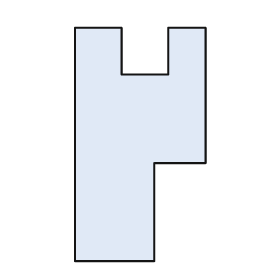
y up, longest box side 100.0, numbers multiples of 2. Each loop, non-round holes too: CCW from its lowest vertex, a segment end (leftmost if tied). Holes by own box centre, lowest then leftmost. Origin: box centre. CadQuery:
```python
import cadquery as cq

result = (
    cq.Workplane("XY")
    .moveTo(-28.0, -50.0)
    .lineTo(6.0, -50.0)
    .lineTo(6.0, -8.0)
    .lineTo(28.0, -8.0)
    .lineTo(28.0, 50.0)
    .lineTo(12.0, 50.0)
    .lineTo(12.0, 30.0)
    .lineTo(-8.0, 30.0)
    .lineTo(-8.0, 50.0)
    .lineTo(-28.0, 50.0)
    .close()
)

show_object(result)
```